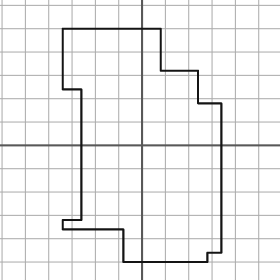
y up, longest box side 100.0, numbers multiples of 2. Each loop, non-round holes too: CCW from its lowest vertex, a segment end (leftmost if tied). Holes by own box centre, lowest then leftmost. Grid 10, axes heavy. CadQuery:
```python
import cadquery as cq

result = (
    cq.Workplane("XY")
    .moveTo(-8.0, -50.0)
    .lineTo(28.0, -50.0)
    .lineTo(28.0, -46.0)
    .lineTo(34.0, -46.0)
    .lineTo(34.0, 18.0)
    .lineTo(24.0, 18.0)
    .lineTo(24.0, 32.0)
    .lineTo(8.0, 32.0)
    .lineTo(8.0, 50.0)
    .lineTo(-34.0, 50.0)
    .lineTo(-34.0, 24.0)
    .lineTo(-26.0, 24.0)
    .lineTo(-26.0, -32.0)
    .lineTo(-34.0, -32.0)
    .lineTo(-34.0, -36.0)
    .lineTo(-8.0, -36.0)
    .close()
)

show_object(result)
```